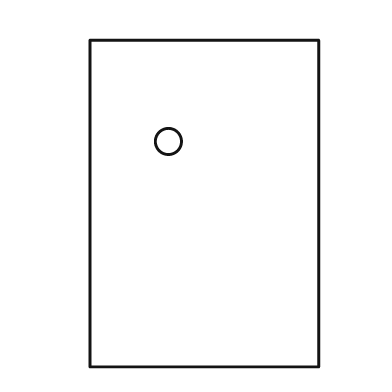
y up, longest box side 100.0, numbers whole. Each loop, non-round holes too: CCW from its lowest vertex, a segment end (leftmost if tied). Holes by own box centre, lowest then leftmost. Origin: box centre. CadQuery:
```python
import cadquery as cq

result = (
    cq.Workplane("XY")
    .moveTo(-35.0, -50.0)
    .lineTo(35.0, -50.0)
    .lineTo(35.0, 50.0)
    .lineTo(-35.0, 50.0)
    .close()
    .moveTo(-11.0, 19.0)
    .circle(4.0)
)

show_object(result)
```